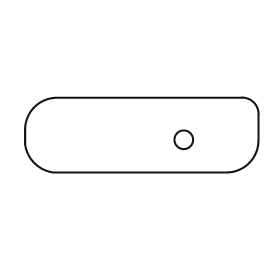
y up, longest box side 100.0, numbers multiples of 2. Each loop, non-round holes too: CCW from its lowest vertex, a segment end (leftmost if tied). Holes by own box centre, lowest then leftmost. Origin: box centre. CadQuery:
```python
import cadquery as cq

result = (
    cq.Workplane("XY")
    .moveTo(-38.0, -16.0)
    .lineTo(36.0, -16.0)
    .threePointArc((46.0, -12.0), (50.0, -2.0))
    .lineTo(50.0, 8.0)
    .threePointArc((48.0, 14.0), (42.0, 16.0))
    .lineTo(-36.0, 16.0)
    .threePointArc((-46.0, 12.0), (-50.0, 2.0))
    .lineTo(-50.0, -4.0)
    .threePointArc((-46.0, -12.0), (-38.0, -16.0))
    .close()
    .moveTo(18.0, -2.0)
    .circle(4.0)
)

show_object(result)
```